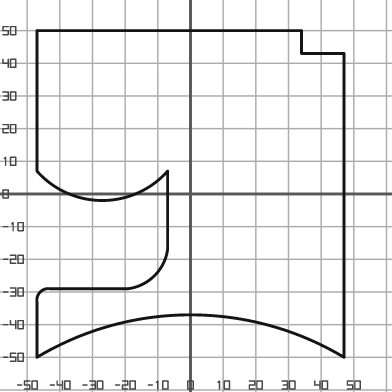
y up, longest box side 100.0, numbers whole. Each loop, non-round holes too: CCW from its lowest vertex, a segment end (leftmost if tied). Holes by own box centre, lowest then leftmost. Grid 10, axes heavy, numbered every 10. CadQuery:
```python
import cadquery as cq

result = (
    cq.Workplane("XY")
    .moveTo(-47.0, -50.0)
    .threePointArc((0.0, -37.0), (47.0, -50.0))
    .lineTo(47.0, 43.0)
    .lineTo(34.0, 43.0)
    .lineTo(34.0, 50.0)
    .lineTo(-47.0, 50.0)
    .lineTo(-47.0, 7.0)
    .threePointArc((-27.0, -2.0), (-7.0, 7.0))
    .lineTo(-7.0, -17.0)
    .threePointArc((-11.0, -25.0), (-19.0, -29.0))
    .lineTo(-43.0, -29.0)
    .threePointArc((-46.0, -30.0), (-47.0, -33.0))
    .close()
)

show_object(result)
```